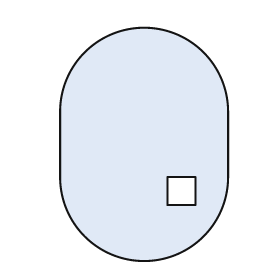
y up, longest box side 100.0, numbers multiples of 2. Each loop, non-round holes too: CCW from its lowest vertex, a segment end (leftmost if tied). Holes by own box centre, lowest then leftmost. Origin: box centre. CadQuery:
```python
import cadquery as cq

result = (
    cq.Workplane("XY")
    .moveTo(-36.0, -14.0)
    .threePointArc((0.0, -50.0), (36.0, -14.0))
    .lineTo(36.0, 14.0)
    .threePointArc((0.0, 50.0), (-36.0, 14.0))
    .close()
    .moveTo(10.0, -26.0)
    .lineTo(22.0, -26.0)
    .lineTo(22.0, -14.0)
    .lineTo(10.0, -14.0)
    .close()
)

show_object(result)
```